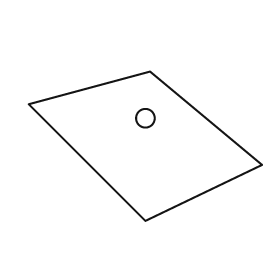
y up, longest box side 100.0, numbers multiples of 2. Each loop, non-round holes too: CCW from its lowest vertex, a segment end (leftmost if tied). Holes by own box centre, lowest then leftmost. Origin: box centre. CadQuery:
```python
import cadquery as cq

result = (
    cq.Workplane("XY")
    .moveTo(0.0, -32.0)
    .lineTo(50.0, -8.0)
    .lineTo(2.0, 32.0)
    .lineTo(-50.0, 18.0)
    .close()
    .moveTo(0.0, 12.0)
    .circle(4.0)
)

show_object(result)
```